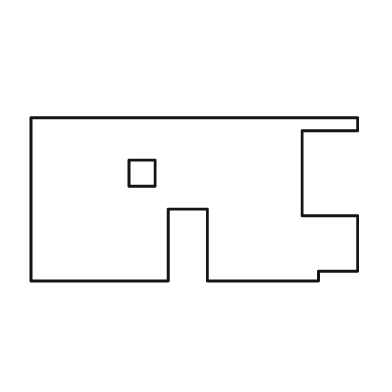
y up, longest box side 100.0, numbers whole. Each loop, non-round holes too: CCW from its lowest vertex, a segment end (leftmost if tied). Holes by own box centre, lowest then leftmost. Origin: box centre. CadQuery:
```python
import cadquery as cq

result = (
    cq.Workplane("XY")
    .moveTo(-50.0, -25.0)
    .lineTo(-8.0, -25.0)
    .lineTo(-8.0, -3.0)
    .lineTo(4.0, -3.0)
    .lineTo(4.0, -25.0)
    .lineTo(38.0, -25.0)
    .lineTo(38.0, -22.0)
    .lineTo(50.0, -22.0)
    .lineTo(50.0, -5.0)
    .lineTo(33.0, -5.0)
    .lineTo(33.0, 21.0)
    .lineTo(50.0, 21.0)
    .lineTo(50.0, 25.0)
    .lineTo(-50.0, 25.0)
    .close()
    .moveTo(-20.0, 4.0)
    .lineTo(-12.0, 4.0)
    .lineTo(-12.0, 12.0)
    .lineTo(-20.0, 12.0)
    .close()
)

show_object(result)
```